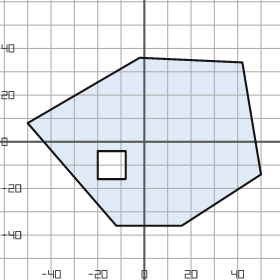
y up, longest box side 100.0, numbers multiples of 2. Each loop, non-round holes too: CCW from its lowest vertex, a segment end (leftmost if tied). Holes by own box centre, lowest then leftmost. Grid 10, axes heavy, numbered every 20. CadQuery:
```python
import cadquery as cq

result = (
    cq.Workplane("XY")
    .moveTo(-12.0, -36.0)
    .lineTo(16.0, -36.0)
    .lineTo(50.0, -14.0)
    .lineTo(42.0, 34.0)
    .lineTo(-2.0, 36.0)
    .lineTo(-50.0, 8.0)
    .close()
    .moveTo(-20.0, -16.0)
    .lineTo(-8.0, -16.0)
    .lineTo(-8.0, -4.0)
    .lineTo(-20.0, -4.0)
    .close()
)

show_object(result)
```